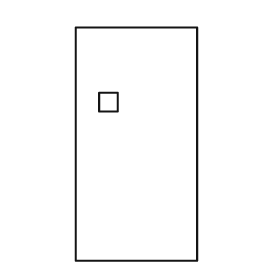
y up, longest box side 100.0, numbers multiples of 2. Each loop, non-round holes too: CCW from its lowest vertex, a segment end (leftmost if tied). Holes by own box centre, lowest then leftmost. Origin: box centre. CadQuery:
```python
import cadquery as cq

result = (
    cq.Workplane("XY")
    .moveTo(-26.0, -50.0)
    .lineTo(26.0, -50.0)
    .lineTo(26.0, 50.0)
    .lineTo(-26.0, 50.0)
    .close()
    .moveTo(-16.0, 14.0)
    .lineTo(-8.0, 14.0)
    .lineTo(-8.0, 22.0)
    .lineTo(-16.0, 22.0)
    .close()
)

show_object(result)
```